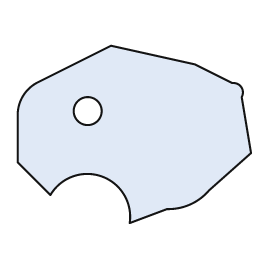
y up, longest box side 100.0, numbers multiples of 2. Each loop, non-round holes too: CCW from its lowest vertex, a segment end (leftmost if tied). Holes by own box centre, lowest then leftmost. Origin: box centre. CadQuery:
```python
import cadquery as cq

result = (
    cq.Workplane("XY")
    .moveTo(-2.0, -38.0)
    .lineTo(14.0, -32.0)
    .threePointArc((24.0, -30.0), (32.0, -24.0))
    .lineTo(50.0, -8.0)
    .lineTo(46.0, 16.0)
    .threePointArc((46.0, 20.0), (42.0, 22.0))
    .lineTo(26.0, 30.0)
    .lineTo(-10.0, 38.0)
    .lineTo(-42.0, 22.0)
    .threePointArc((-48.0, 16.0), (-50.0, 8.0))
    .lineTo(-50.0, -12.0)
    .lineTo(-36.0, -26.0)
    .threePointArc((-14.0, -18.0), (-2.0, -38.0))
    .close()
    .moveTo(-20.0, 10.0)
    .circle(6.0)
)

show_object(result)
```